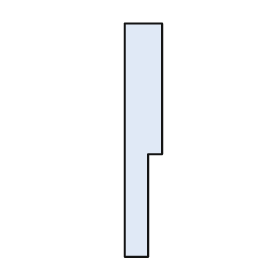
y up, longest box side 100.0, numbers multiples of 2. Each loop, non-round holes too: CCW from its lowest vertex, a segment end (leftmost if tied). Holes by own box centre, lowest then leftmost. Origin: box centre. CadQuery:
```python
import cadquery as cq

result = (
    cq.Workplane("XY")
    .moveTo(-8.0, -50.0)
    .lineTo(2.0, -50.0)
    .lineTo(2.0, -6.0)
    .lineTo(8.0, -6.0)
    .lineTo(8.0, 50.0)
    .lineTo(-8.0, 50.0)
    .close()
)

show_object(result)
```